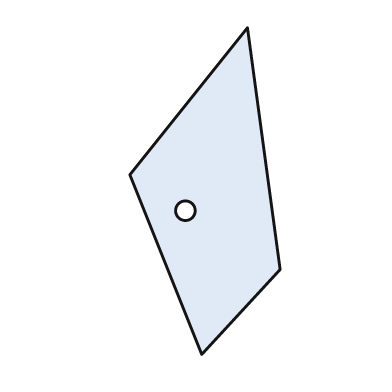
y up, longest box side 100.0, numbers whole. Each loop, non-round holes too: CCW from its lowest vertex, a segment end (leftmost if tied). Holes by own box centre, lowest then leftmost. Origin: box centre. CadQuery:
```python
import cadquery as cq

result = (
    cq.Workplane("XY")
    .moveTo(-1.0, -50.0)
    .lineTo(23.0, -24.0)
    .lineTo(13.0, 50.0)
    .lineTo(-23.0, 5.0)
    .close()
    .moveTo(-6.0, -6.0)
    .circle(3.0)
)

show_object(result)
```